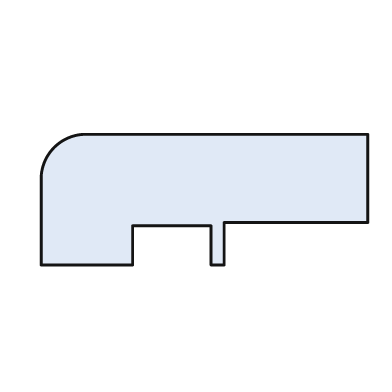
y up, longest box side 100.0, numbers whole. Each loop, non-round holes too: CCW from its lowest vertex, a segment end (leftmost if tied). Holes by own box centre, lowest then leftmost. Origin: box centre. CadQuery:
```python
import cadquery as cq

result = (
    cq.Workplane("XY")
    .moveTo(-50.0, -20.0)
    .lineTo(-22.0, -20.0)
    .lineTo(-22.0, -8.0)
    .lineTo(2.0, -8.0)
    .lineTo(2.0, -20.0)
    .lineTo(6.0, -20.0)
    .lineTo(6.0, -7.0)
    .lineTo(50.0, -7.0)
    .lineTo(50.0, 20.0)
    .lineTo(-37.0, 20.0)
    .threePointArc((-46.0, 16.0), (-50.0, 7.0))
    .close()
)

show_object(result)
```